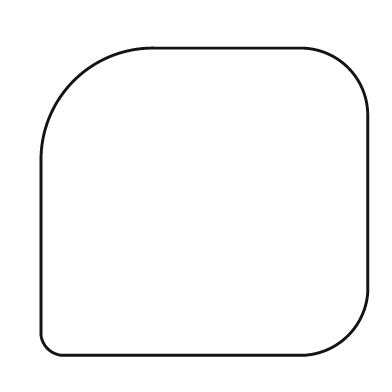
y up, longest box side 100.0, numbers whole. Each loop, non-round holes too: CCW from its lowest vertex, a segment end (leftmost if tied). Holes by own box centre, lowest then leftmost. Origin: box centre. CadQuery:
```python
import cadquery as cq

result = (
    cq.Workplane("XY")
    .moveTo(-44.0, -47.0)
    .lineTo(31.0, -47.0)
    .threePointArc((44.0, -41.0), (50.0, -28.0))
    .lineTo(50.0, 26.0)
    .threePointArc((44.0, 41.0), (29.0, 47.0))
    .lineTo(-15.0, 47.0)
    .threePointArc((-40.0, 37.0), (-50.0, 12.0))
    .lineTo(-50.0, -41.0)
    .threePointArc((-48.0, -45.0), (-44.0, -47.0))
    .close()
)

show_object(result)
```